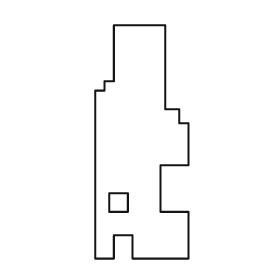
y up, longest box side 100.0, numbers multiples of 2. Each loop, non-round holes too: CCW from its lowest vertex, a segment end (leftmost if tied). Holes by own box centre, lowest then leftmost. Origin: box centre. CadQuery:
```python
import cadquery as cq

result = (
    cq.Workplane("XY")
    .moveTo(-20.0, -50.0)
    .lineTo(-12.0, -50.0)
    .lineTo(-12.0, -40.0)
    .lineTo(-4.0, -40.0)
    .lineTo(-4.0, -50.0)
    .lineTo(20.0, -50.0)
    .lineTo(20.0, -30.0)
    .lineTo(8.0, -30.0)
    .lineTo(8.0, -10.0)
    .lineTo(20.0, -10.0)
    .lineTo(20.0, 8.0)
    .lineTo(16.0, 8.0)
    .lineTo(16.0, 14.0)
    .lineTo(10.0, 14.0)
    .lineTo(10.0, 50.0)
    .lineTo(-12.0, 50.0)
    .lineTo(-12.0, 26.0)
    .lineTo(-16.0, 26.0)
    .lineTo(-16.0, 22.0)
    .lineTo(-20.0, 22.0)
    .close()
    .moveTo(-14.0, -30.0)
    .lineTo(-6.0, -30.0)
    .lineTo(-6.0, -22.0)
    .lineTo(-14.0, -22.0)
    .close()
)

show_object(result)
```